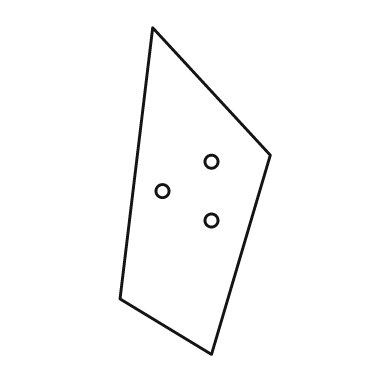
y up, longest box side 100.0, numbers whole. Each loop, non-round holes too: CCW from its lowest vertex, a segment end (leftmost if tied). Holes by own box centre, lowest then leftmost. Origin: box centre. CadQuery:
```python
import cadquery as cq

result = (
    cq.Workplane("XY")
    .moveTo(5.0, -50.0)
    .lineTo(23.0, 11.0)
    .lineTo(-13.0, 50.0)
    .lineTo(-23.0, -33.0)
    .close()
    .moveTo(5.0, -9.0)
    .circle(2.0)
    .moveTo(-10.0, 0.0)
    .circle(2.0)
    .moveTo(5.0, 9.0)
    .circle(2.0)
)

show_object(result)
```